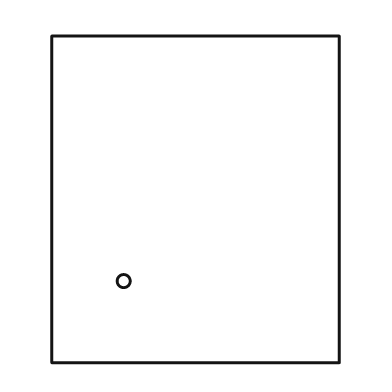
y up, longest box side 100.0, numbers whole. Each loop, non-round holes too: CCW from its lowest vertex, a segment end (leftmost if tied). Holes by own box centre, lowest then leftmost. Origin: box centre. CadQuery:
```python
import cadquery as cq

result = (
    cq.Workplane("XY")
    .moveTo(-44.0, -50.0)
    .lineTo(44.0, -50.0)
    .lineTo(44.0, 50.0)
    .lineTo(-44.0, 50.0)
    .close()
    .moveTo(-22.0, -25.0)
    .circle(2.0)
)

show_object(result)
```